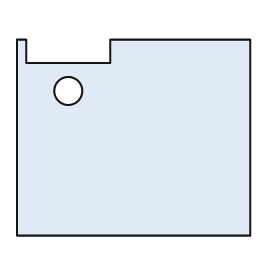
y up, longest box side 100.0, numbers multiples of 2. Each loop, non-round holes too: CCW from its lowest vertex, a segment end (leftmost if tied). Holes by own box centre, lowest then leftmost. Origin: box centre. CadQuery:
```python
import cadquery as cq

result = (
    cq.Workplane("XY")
    .moveTo(-50.0, -42.0)
    .lineTo(50.0, -42.0)
    .lineTo(50.0, 42.0)
    .lineTo(-10.0, 42.0)
    .lineTo(-10.0, 32.0)
    .lineTo(-46.0, 32.0)
    .lineTo(-46.0, 42.0)
    .lineTo(-50.0, 42.0)
    .close()
    .moveTo(-28.0, 20.0)
    .circle(6.0)
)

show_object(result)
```